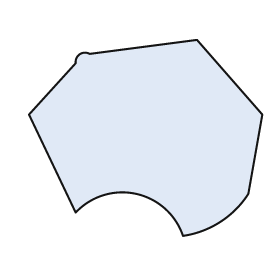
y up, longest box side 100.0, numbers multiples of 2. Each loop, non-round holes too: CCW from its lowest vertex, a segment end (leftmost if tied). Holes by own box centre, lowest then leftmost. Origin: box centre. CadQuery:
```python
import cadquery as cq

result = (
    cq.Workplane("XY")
    .moveTo(16.0, -42.0)
    .threePointArc((32.0, -36.0), (44.0, -24.0))
    .lineTo(50.0, 10.0)
    .lineTo(22.0, 42.0)
    .lineTo(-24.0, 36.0)
    .threePointArc((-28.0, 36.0), (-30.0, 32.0))
    .lineTo(-50.0, 10.0)
    .lineTo(-30.0, -32.0)
    .threePointArc((-4.0, -24.0), (16.0, -42.0))
    .close()
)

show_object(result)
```